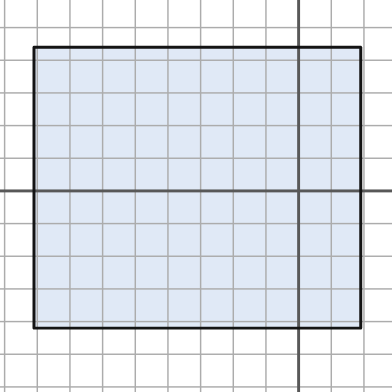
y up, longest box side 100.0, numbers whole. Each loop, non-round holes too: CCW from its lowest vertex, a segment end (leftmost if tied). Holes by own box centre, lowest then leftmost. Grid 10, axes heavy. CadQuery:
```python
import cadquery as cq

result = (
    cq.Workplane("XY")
    .moveTo(-81.0, -42.0)
    .lineTo(19.0, -42.0)
    .lineTo(19.0, 44.0)
    .lineTo(-81.0, 44.0)
    .close()
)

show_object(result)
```